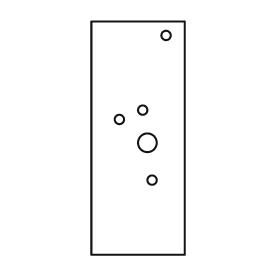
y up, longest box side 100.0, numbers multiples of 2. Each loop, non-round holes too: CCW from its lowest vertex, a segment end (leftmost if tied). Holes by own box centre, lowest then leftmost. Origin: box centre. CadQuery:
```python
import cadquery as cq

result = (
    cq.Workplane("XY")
    .moveTo(-20.0, -50.0)
    .lineTo(20.0, -50.0)
    .lineTo(20.0, 50.0)
    .lineTo(-20.0, 50.0)
    .close()
    .moveTo(6.0, -18.0)
    .circle(2.0)
    .moveTo(4.0, -2.0)
    .circle(4.0)
    .moveTo(-8.0, 8.0)
    .circle(2.0)
    .moveTo(2.0, 12.0)
    .circle(2.0)
    .moveTo(12.0, 44.0)
    .circle(2.0)
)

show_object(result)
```